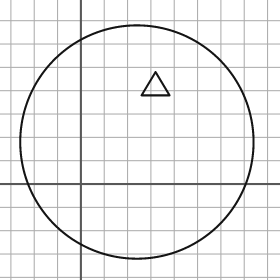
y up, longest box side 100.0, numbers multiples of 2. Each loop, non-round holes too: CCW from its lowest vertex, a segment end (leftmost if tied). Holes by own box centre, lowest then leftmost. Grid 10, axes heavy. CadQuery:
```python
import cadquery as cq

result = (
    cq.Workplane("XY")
    .moveTo(24.0, 18.0)
    .circle(50.0)
    .moveTo(26.0, 38.0)
    .lineTo(38.0, 38.0)
    .lineTo(32.0, 48.0)
    .close()
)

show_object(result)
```